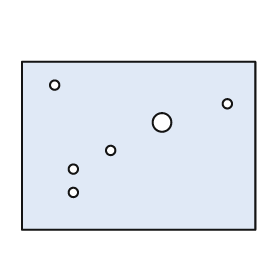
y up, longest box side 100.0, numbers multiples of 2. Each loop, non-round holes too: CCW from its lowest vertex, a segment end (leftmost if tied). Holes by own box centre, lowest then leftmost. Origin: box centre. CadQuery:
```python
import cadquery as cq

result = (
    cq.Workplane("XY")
    .moveTo(-50.0, -36.0)
    .lineTo(50.0, -36.0)
    .lineTo(50.0, 36.0)
    .lineTo(-50.0, 36.0)
    .close()
    .moveTo(-28.0, -20.0)
    .circle(2.0)
    .moveTo(-28.0, -10.0)
    .circle(2.0)
    .moveTo(-12.0, -2.0)
    .circle(2.0)
    .moveTo(10.0, 10.0)
    .circle(4.0)
    .moveTo(38.0, 18.0)
    .circle(2.0)
    .moveTo(-36.0, 26.0)
    .circle(2.0)
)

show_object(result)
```